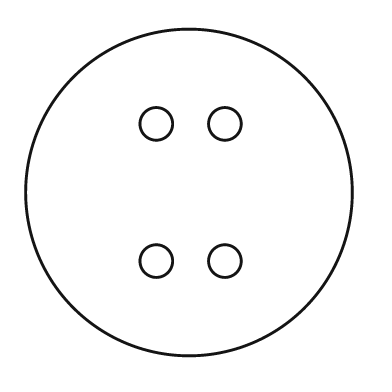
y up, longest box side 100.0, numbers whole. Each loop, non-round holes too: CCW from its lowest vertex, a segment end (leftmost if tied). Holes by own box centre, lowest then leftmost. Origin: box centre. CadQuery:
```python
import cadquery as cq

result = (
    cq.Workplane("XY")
    .moveTo(0.0, 0.0)
    .circle(50.0)
    .moveTo(-10.0, -21.0)
    .circle(5.0)
    .moveTo(11.0, -21.0)
    .circle(5.0)
    .moveTo(-10.0, 21.0)
    .circle(5.0)
    .moveTo(11.0, 21.0)
    .circle(5.0)
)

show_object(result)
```